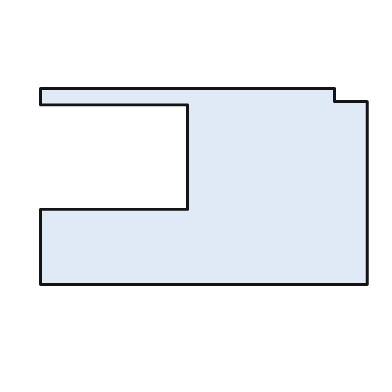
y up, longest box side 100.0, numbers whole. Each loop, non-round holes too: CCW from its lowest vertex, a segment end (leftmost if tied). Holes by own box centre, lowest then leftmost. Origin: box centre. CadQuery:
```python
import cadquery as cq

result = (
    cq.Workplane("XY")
    .moveTo(-50.0, -30.0)
    .lineTo(50.0, -30.0)
    .lineTo(50.0, 26.0)
    .lineTo(40.0, 26.0)
    .lineTo(40.0, 30.0)
    .lineTo(-50.0, 30.0)
    .lineTo(-50.0, 25.0)
    .lineTo(-5.0, 25.0)
    .lineTo(-5.0, -7.0)
    .lineTo(-50.0, -7.0)
    .close()
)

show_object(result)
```